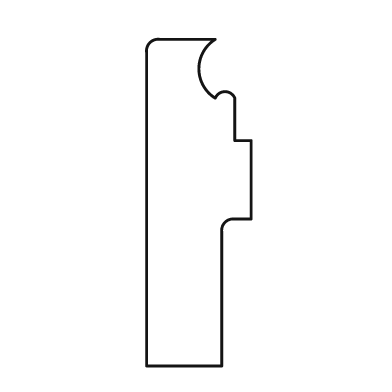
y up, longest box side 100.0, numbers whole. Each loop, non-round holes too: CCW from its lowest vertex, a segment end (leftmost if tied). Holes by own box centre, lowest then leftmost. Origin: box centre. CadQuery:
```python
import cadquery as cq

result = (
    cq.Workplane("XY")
    .moveTo(-16.0, -50.0)
    .lineTo(7.0, -50.0)
    .lineTo(7.0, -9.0)
    .threePointArc((8.0, -6.0), (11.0, -5.0))
    .lineTo(16.0, -5.0)
    .lineTo(16.0, 19.0)
    .lineTo(11.0, 19.0)
    .lineTo(11.0, 32.0)
    .threePointArc((8.0, 34.0), (5.0, 32.0))
    .threePointArc((0.0, 41.0), (5.0, 50.0))
    .lineTo(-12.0, 50.0)
    .threePointArc((-15.0, 49.0), (-16.0, 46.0))
    .close()
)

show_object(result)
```